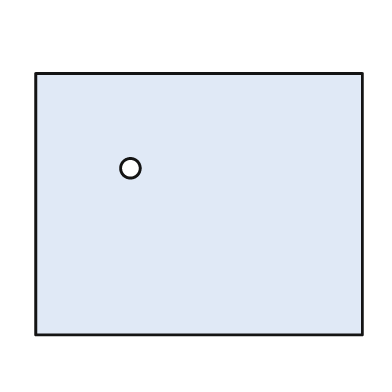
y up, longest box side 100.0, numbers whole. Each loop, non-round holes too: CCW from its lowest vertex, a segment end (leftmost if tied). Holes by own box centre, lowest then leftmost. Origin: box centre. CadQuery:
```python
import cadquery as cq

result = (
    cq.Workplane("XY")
    .moveTo(-50.0, -40.0)
    .lineTo(50.0, -40.0)
    .lineTo(50.0, 40.0)
    .lineTo(-50.0, 40.0)
    .close()
    .moveTo(-21.0, 11.0)
    .circle(3.0)
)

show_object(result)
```